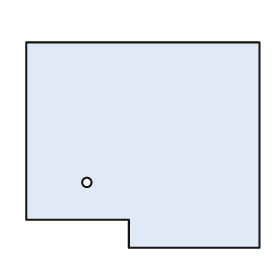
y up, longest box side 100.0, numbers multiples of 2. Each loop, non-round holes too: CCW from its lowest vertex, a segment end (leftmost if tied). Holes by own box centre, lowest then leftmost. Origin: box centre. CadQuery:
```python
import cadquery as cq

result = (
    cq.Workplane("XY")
    .moveTo(-6.0, -44.0)
    .lineTo(50.0, -44.0)
    .lineTo(50.0, 44.0)
    .lineTo(-50.0, 44.0)
    .lineTo(-50.0, -32.0)
    .lineTo(-6.0, -32.0)
    .close()
    .moveTo(-24.0, -16.0)
    .circle(2.0)
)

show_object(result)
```